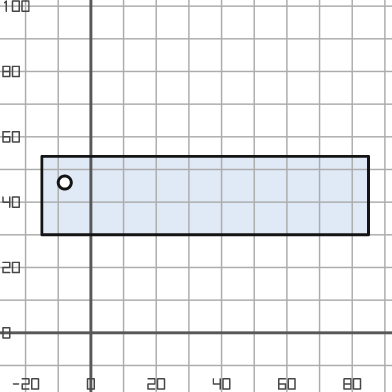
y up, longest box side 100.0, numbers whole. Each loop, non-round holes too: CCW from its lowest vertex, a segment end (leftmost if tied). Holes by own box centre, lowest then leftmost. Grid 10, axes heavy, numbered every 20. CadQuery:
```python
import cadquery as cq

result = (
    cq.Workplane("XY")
    .moveTo(-15.0, 30.0)
    .lineTo(85.0, 30.0)
    .lineTo(85.0, 54.0)
    .lineTo(-15.0, 54.0)
    .close()
    .moveTo(-8.0, 46.0)
    .circle(2.0)
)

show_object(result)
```